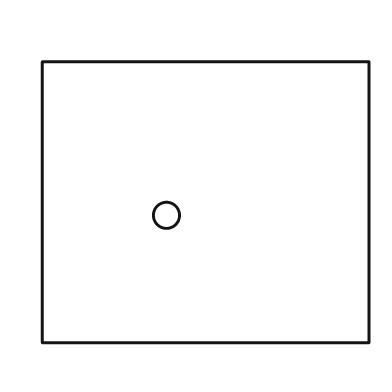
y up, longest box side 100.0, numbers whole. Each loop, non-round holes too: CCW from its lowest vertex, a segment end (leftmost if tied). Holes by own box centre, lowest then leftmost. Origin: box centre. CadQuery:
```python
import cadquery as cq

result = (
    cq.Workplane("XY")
    .moveTo(-50.0, -43.0)
    .lineTo(50.0, -43.0)
    .lineTo(50.0, 43.0)
    .lineTo(-50.0, 43.0)
    .close()
    .moveTo(-12.0, -4.0)
    .circle(4.0)
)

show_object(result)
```